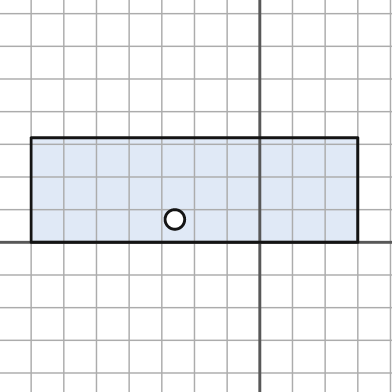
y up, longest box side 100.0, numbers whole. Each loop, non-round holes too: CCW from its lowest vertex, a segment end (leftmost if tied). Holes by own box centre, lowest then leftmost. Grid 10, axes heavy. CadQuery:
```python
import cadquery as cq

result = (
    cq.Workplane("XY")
    .moveTo(-70.0, 0.0)
    .lineTo(30.0, 0.0)
    .lineTo(30.0, 32.0)
    .lineTo(-70.0, 32.0)
    .close()
    .moveTo(-26.0, 7.0)
    .circle(3.0)
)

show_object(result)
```